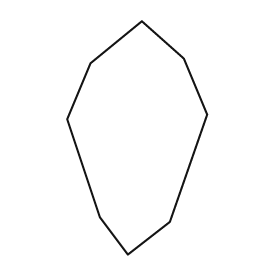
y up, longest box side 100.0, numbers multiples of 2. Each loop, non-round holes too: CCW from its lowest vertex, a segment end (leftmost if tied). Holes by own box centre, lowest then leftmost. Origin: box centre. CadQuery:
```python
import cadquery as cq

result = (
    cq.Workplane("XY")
    .moveTo(-4.0, -50.0)
    .lineTo(14.0, -36.0)
    .lineTo(30.0, 10.0)
    .lineTo(20.0, 34.0)
    .lineTo(2.0, 50.0)
    .lineTo(-20.0, 32.0)
    .lineTo(-30.0, 8.0)
    .lineTo(-16.0, -34.0)
    .close()
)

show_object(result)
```